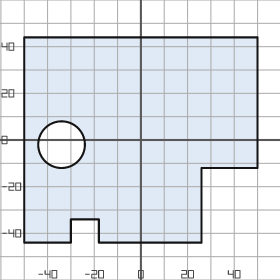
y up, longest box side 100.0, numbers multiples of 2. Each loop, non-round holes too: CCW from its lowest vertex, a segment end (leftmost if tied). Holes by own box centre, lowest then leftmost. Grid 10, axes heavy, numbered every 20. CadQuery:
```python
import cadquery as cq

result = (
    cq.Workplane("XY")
    .moveTo(-50.0, -44.0)
    .lineTo(-30.0, -44.0)
    .lineTo(-30.0, -34.0)
    .lineTo(-18.0, -34.0)
    .lineTo(-18.0, -44.0)
    .lineTo(26.0, -44.0)
    .lineTo(26.0, -12.0)
    .lineTo(50.0, -12.0)
    .lineTo(50.0, 44.0)
    .lineTo(-50.0, 44.0)
    .close()
    .moveTo(-34.0, -2.0)
    .circle(10.0)
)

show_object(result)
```